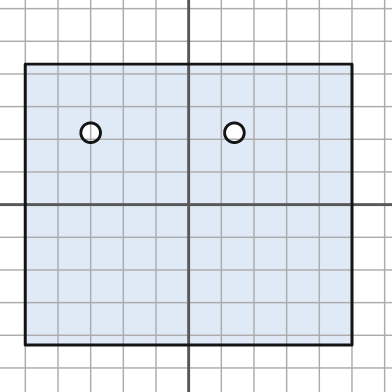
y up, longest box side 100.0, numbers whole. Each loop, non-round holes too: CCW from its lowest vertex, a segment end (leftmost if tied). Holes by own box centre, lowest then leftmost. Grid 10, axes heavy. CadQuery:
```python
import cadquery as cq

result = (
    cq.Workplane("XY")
    .moveTo(-50.0, -43.0)
    .lineTo(50.0, -43.0)
    .lineTo(50.0, 43.0)
    .lineTo(-50.0, 43.0)
    .close()
    .moveTo(-30.0, 22.0)
    .circle(3.0)
    .moveTo(14.0, 22.0)
    .circle(3.0)
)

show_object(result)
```